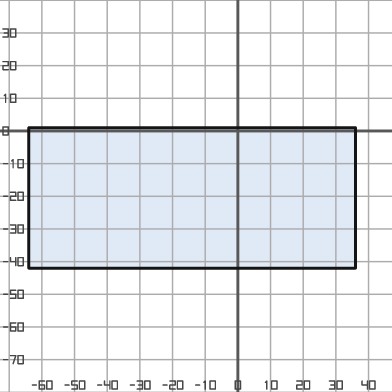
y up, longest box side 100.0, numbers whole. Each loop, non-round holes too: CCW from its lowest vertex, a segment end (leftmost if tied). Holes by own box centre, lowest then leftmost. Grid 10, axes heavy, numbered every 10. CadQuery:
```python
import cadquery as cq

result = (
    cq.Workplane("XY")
    .moveTo(-64.0, -42.0)
    .lineTo(36.0, -42.0)
    .lineTo(36.0, 1.0)
    .lineTo(-64.0, 1.0)
    .close()
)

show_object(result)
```